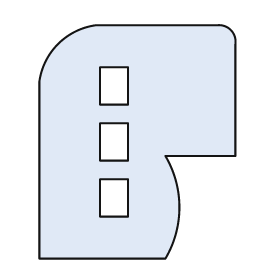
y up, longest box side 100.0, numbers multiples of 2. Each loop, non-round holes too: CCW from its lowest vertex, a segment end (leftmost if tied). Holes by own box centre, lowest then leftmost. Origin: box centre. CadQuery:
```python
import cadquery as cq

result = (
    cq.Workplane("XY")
    .moveTo(-42.0, -50.0)
    .lineTo(12.0, -50.0)
    .threePointArc((18.0, -28.0), (12.0, -6.0))
    .lineTo(42.0, -6.0)
    .lineTo(42.0, 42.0)
    .threePointArc((40.0, 48.0), (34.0, 50.0))
    .lineTo(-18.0, 50.0)
    .threePointArc((-34.0, 42.0), (-42.0, 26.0))
    .close()
    .moveTo(-16.0, -32.0)
    .lineTo(-4.0, -32.0)
    .lineTo(-4.0, -16.0)
    .lineTo(-16.0, -16.0)
    .close()
    .moveTo(-16.0, -8.0)
    .lineTo(-4.0, -8.0)
    .lineTo(-4.0, 8.0)
    .lineTo(-16.0, 8.0)
    .close()
    .moveTo(-16.0, 16.0)
    .lineTo(-4.0, 16.0)
    .lineTo(-4.0, 32.0)
    .lineTo(-16.0, 32.0)
    .close()
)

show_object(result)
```